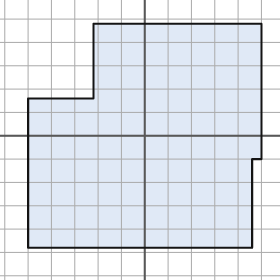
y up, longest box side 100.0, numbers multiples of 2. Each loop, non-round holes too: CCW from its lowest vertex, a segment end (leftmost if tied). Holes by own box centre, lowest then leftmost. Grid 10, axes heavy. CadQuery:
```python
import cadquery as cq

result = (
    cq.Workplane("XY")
    .moveTo(-50.0, -48.0)
    .lineTo(46.0, -48.0)
    .lineTo(46.0, -10.0)
    .lineTo(50.0, -10.0)
    .lineTo(50.0, 48.0)
    .lineTo(-22.0, 48.0)
    .lineTo(-22.0, 16.0)
    .lineTo(-50.0, 16.0)
    .close()
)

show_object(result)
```